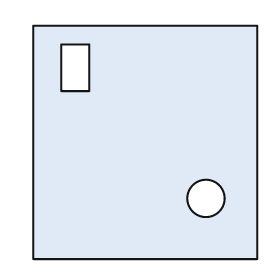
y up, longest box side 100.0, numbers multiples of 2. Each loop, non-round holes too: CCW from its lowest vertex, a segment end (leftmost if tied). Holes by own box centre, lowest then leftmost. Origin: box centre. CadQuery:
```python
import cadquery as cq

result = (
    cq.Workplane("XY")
    .moveTo(-48.0, -50.0)
    .lineTo(48.0, -50.0)
    .lineTo(48.0, 50.0)
    .lineTo(-48.0, 50.0)
    .close()
    .moveTo(26.0, -24.0)
    .circle(8.0)
    .moveTo(-36.0, 22.0)
    .lineTo(-24.0, 22.0)
    .lineTo(-24.0, 42.0)
    .lineTo(-36.0, 42.0)
    .close()
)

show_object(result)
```